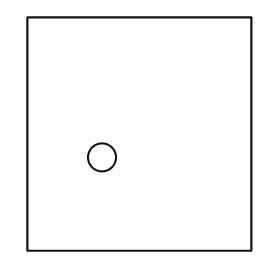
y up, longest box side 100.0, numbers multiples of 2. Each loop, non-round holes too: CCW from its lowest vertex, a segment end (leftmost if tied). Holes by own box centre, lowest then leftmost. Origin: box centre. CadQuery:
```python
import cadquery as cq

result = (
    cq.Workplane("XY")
    .moveTo(-48.0, -50.0)
    .lineTo(48.0, -50.0)
    .lineTo(48.0, 50.0)
    .lineTo(-48.0, 50.0)
    .close()
    .moveTo(-16.0, -10.0)
    .circle(6.0)
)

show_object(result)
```